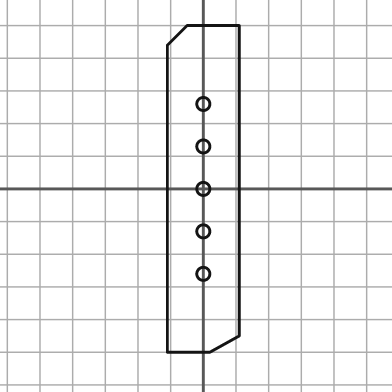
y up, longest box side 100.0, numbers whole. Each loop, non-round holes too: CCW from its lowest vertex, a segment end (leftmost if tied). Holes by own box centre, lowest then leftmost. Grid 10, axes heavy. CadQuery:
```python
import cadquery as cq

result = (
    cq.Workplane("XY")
    .moveTo(-11.0, -50.0)
    .lineTo(2.0, -50.0)
    .lineTo(11.0, -45.0)
    .lineTo(11.0, 50.0)
    .lineTo(-5.0, 50.0)
    .lineTo(-11.0, 44.0)
    .close()
    .moveTo(0.0, -26.0)
    .circle(2.0)
    .moveTo(0.0, -13.0)
    .circle(2.0)
    .moveTo(0.0, 0.0)
    .circle(2.0)
    .moveTo(0.0, 13.0)
    .circle(2.0)
    .moveTo(0.0, 26.0)
    .circle(2.0)
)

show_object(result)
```